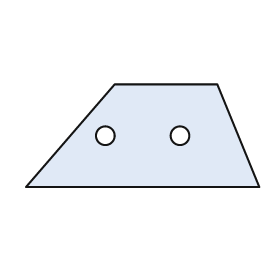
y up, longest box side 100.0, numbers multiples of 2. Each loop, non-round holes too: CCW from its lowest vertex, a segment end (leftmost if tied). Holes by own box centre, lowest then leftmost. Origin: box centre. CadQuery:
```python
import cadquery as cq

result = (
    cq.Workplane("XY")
    .moveTo(-50.0, -22.0)
    .lineTo(50.0, -22.0)
    .lineTo(32.0, 22.0)
    .lineTo(-12.0, 22.0)
    .close()
    .moveTo(-16.0, 0.0)
    .circle(4.0)
    .moveTo(16.0, 0.0)
    .circle(4.0)
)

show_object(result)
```